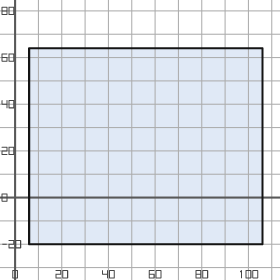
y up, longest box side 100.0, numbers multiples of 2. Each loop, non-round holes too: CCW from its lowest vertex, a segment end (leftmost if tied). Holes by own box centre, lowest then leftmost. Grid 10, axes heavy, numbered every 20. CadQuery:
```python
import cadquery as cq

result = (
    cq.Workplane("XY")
    .moveTo(6.0, -20.0)
    .lineTo(106.0, -20.0)
    .lineTo(106.0, 64.0)
    .lineTo(6.0, 64.0)
    .close()
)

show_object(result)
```